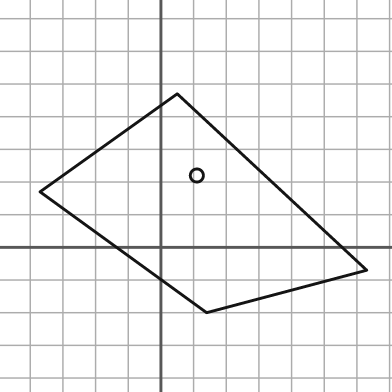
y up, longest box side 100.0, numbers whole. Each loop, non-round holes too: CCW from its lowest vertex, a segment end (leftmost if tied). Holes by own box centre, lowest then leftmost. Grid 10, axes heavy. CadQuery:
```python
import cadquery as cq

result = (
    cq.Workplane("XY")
    .moveTo(14.0, -20.0)
    .lineTo(63.0, -7.0)
    .lineTo(5.0, 47.0)
    .lineTo(-37.0, 17.0)
    .close()
    .moveTo(11.0, 22.0)
    .circle(2.0)
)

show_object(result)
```